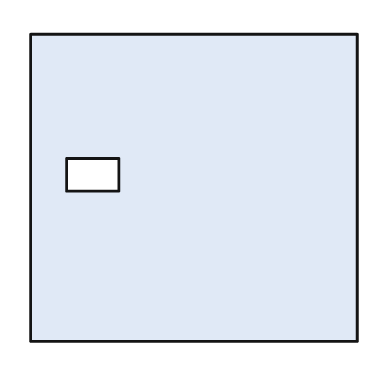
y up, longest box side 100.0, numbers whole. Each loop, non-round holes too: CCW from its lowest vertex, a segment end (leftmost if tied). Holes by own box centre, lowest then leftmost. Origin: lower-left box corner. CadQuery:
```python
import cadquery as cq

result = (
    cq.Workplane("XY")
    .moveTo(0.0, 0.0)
    .lineTo(100.0, 0.0)
    .lineTo(100.0, 94.0)
    .lineTo(0.0, 94.0)
    .close()
    .moveTo(11.0, 46.0)
    .lineTo(27.0, 46.0)
    .lineTo(27.0, 56.0)
    .lineTo(11.0, 56.0)
    .close()
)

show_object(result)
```